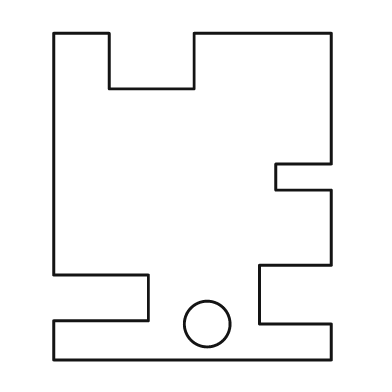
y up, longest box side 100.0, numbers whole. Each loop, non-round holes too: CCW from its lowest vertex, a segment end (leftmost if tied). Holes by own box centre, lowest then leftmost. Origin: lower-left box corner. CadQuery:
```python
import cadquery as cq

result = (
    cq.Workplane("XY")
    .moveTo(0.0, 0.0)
    .lineTo(85.0, 0.0)
    .lineTo(85.0, 11.0)
    .lineTo(63.0, 11.0)
    .lineTo(63.0, 29.0)
    .lineTo(85.0, 29.0)
    .lineTo(85.0, 52.0)
    .lineTo(68.0, 52.0)
    .lineTo(68.0, 60.0)
    .lineTo(85.0, 60.0)
    .lineTo(85.0, 100.0)
    .lineTo(43.0, 100.0)
    .lineTo(43.0, 83.0)
    .lineTo(17.0, 83.0)
    .lineTo(17.0, 100.0)
    .lineTo(0.0, 100.0)
    .lineTo(0.0, 26.0)
    .lineTo(29.0, 26.0)
    .lineTo(29.0, 12.0)
    .lineTo(0.0, 12.0)
    .close()
    .moveTo(47.0, 11.0)
    .circle(7.0)
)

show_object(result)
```